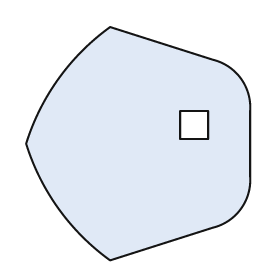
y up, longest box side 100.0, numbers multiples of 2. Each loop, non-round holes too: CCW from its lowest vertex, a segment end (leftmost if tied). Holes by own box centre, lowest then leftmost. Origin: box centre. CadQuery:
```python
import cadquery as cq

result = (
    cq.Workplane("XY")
    .moveTo(-12.0, -50.0)
    .lineTo(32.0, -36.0)
    .threePointArc((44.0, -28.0), (48.0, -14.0))
    .lineTo(48.0, 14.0)
    .threePointArc((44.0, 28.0), (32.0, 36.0))
    .lineTo(-12.0, 50.0)
    .threePointArc((-34.0, 28.0), (-48.0, 0.0))
    .threePointArc((-34.0, -28.0), (-12.0, -50.0))
    .close()
    .moveTo(18.0, 2.0)
    .lineTo(30.0, 2.0)
    .lineTo(30.0, 14.0)
    .lineTo(18.0, 14.0)
    .close()
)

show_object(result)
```